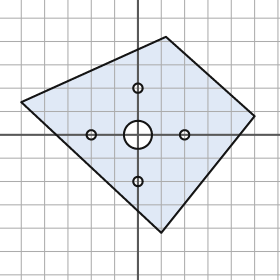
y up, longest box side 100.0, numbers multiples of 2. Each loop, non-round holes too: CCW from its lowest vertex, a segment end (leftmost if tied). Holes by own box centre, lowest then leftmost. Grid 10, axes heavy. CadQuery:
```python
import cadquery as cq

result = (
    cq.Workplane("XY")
    .moveTo(10.0, -42.0)
    .lineTo(50.0, 8.0)
    .lineTo(12.0, 42.0)
    .lineTo(-50.0, 14.0)
    .close()
    .moveTo(0.0, -20.0)
    .circle(2.0)
    .moveTo(-20.0, 0.0)
    .circle(2.0)
    .moveTo(0.0, 0.0)
    .circle(6.0)
    .moveTo(20.0, 0.0)
    .circle(2.0)
    .moveTo(0.0, 20.0)
    .circle(2.0)
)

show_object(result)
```